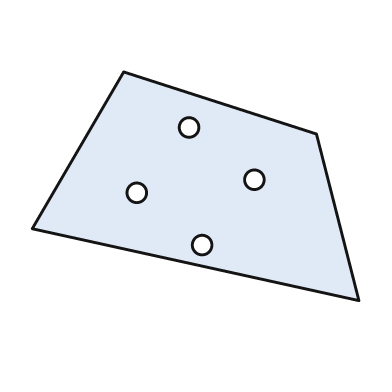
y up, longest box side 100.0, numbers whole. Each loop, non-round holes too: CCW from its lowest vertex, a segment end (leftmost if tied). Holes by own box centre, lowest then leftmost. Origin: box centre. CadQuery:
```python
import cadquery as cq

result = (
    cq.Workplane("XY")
    .moveTo(50.0, -35.0)
    .lineTo(37.0, 16.0)
    .lineTo(-22.0, 35.0)
    .lineTo(-50.0, -13.0)
    .close()
    .moveTo(2.0, -18.0)
    .circle(3.0)
    .moveTo(-18.0, -2.0)
    .circle(3.0)
    .moveTo(18.0, 2.0)
    .circle(3.0)
    .moveTo(-2.0, 18.0)
    .circle(3.0)
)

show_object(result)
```